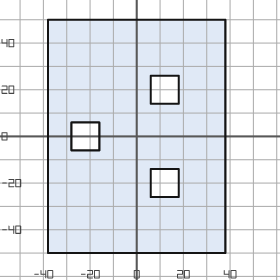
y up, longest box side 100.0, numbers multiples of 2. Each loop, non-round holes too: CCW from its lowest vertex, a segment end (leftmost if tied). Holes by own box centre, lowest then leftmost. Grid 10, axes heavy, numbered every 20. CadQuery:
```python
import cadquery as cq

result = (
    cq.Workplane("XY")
    .moveTo(-38.0, -50.0)
    .lineTo(38.0, -50.0)
    .lineTo(38.0, 50.0)
    .lineTo(-38.0, 50.0)
    .close()
    .moveTo(6.0, -26.0)
    .lineTo(18.0, -26.0)
    .lineTo(18.0, -14.0)
    .lineTo(6.0, -14.0)
    .close()
    .moveTo(-28.0, -6.0)
    .lineTo(-16.0, -6.0)
    .lineTo(-16.0, 6.0)
    .lineTo(-28.0, 6.0)
    .close()
    .moveTo(6.0, 14.0)
    .lineTo(18.0, 14.0)
    .lineTo(18.0, 26.0)
    .lineTo(6.0, 26.0)
    .close()
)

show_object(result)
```